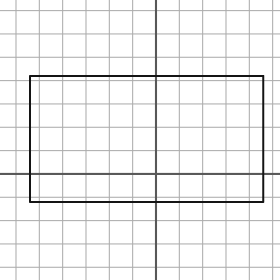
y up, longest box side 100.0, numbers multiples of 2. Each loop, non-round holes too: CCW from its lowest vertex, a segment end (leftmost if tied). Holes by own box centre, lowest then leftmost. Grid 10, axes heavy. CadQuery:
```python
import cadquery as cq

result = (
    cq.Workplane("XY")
    .moveTo(-54.0, -12.0)
    .lineTo(46.0, -12.0)
    .lineTo(46.0, 42.0)
    .lineTo(-54.0, 42.0)
    .close()
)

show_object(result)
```